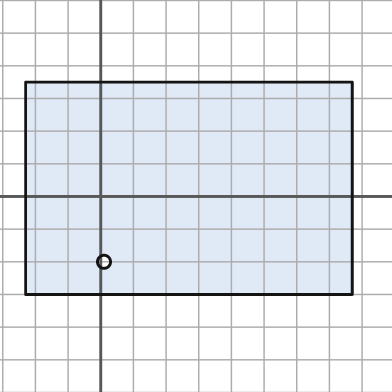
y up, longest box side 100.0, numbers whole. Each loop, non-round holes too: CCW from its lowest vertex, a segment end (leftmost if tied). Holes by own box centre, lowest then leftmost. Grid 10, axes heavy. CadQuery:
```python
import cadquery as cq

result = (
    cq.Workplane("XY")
    .moveTo(-23.0, -30.0)
    .lineTo(77.0, -30.0)
    .lineTo(77.0, 35.0)
    .lineTo(-23.0, 35.0)
    .close()
    .moveTo(1.0, -20.0)
    .circle(2.0)
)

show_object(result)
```